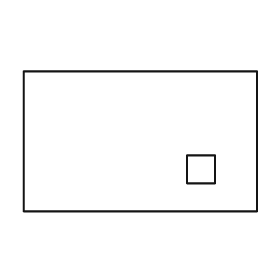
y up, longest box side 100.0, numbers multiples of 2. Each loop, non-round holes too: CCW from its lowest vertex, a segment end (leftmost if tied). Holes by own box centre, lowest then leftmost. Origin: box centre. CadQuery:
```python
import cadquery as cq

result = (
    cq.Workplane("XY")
    .moveTo(-50.0, -30.0)
    .lineTo(50.0, -30.0)
    .lineTo(50.0, 30.0)
    .lineTo(-50.0, 30.0)
    .close()
    .moveTo(20.0, -18.0)
    .lineTo(32.0, -18.0)
    .lineTo(32.0, -6.0)
    .lineTo(20.0, -6.0)
    .close()
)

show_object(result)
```